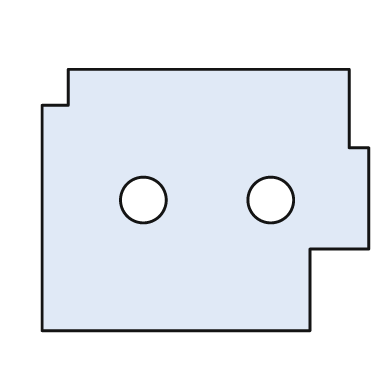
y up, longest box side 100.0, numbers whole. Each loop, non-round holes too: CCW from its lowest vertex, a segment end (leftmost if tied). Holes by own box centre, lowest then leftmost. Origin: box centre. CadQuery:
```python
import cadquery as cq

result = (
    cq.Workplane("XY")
    .moveTo(-50.0, -40.0)
    .lineTo(32.0, -40.0)
    .lineTo(32.0, -15.0)
    .lineTo(50.0, -15.0)
    .lineTo(50.0, 16.0)
    .lineTo(44.0, 16.0)
    .lineTo(44.0, 40.0)
    .lineTo(-42.0, 40.0)
    .lineTo(-42.0, 29.0)
    .lineTo(-50.0, 29.0)
    .close()
    .moveTo(-19.0, 0.0)
    .circle(7.0)
    .moveTo(20.0, 0.0)
    .circle(7.0)
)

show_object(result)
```